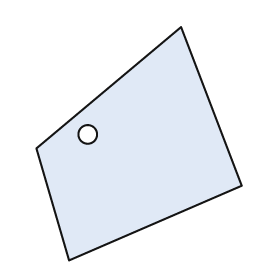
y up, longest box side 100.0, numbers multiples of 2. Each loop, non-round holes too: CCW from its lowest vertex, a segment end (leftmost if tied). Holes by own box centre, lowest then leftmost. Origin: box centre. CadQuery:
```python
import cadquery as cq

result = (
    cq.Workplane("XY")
    .moveTo(-30.0, -50.0)
    .lineTo(44.0, -18.0)
    .lineTo(18.0, 50.0)
    .lineTo(-44.0, -2.0)
    .close()
    .moveTo(-22.0, 4.0)
    .circle(4.0)
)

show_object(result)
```